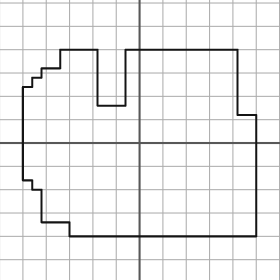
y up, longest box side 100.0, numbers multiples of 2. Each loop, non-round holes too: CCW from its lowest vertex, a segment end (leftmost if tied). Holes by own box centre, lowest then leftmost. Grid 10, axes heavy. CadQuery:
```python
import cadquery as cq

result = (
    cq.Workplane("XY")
    .moveTo(-30.0, -40.0)
    .lineTo(50.0, -40.0)
    .lineTo(50.0, 12.0)
    .lineTo(42.0, 12.0)
    .lineTo(42.0, 40.0)
    .lineTo(-6.0, 40.0)
    .lineTo(-6.0, 16.0)
    .lineTo(-18.0, 16.0)
    .lineTo(-18.0, 40.0)
    .lineTo(-34.0, 40.0)
    .lineTo(-34.0, 32.0)
    .lineTo(-42.0, 32.0)
    .lineTo(-42.0, 28.0)
    .lineTo(-46.0, 28.0)
    .lineTo(-46.0, 24.0)
    .lineTo(-50.0, 24.0)
    .lineTo(-50.0, -16.0)
    .lineTo(-46.0, -16.0)
    .lineTo(-46.0, -20.0)
    .lineTo(-42.0, -20.0)
    .lineTo(-42.0, -34.0)
    .lineTo(-30.0, -34.0)
    .close()
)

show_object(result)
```